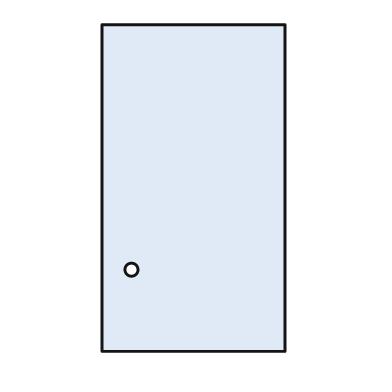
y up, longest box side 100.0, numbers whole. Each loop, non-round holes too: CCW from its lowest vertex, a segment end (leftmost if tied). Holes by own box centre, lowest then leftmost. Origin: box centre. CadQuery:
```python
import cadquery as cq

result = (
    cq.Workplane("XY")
    .moveTo(-28.0, -50.0)
    .lineTo(28.0, -50.0)
    .lineTo(28.0, 50.0)
    .lineTo(-28.0, 50.0)
    .close()
    .moveTo(-19.0, -25.0)
    .circle(2.0)
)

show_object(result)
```